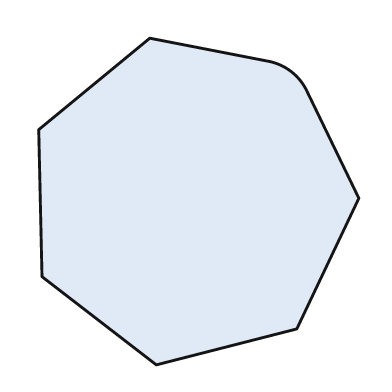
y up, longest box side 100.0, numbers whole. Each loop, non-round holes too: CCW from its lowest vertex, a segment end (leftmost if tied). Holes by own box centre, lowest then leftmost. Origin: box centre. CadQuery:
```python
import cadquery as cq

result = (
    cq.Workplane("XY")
    .moveTo(-13.0, -50.0)
    .lineTo(30.0, -39.0)
    .lineTo(49.0, 1.0)
    .lineTo(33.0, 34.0)
    .threePointArc((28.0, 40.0), (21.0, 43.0))
    .lineTo(-15.0, 50.0)
    .lineTo(-49.0, 22.0)
    .lineTo(-48.0, -23.0)
    .close()
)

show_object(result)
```